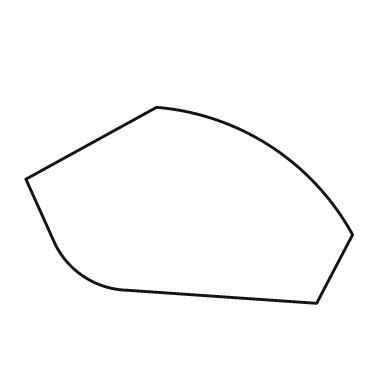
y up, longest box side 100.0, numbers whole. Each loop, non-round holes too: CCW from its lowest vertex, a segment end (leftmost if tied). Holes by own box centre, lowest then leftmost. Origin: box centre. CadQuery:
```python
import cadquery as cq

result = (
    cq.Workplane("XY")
    .moveTo(39.0, -30.0)
    .lineTo(50.0, -9.0)
    .threePointArc((25.0, 18.0), (-10.0, 30.0))
    .lineTo(-50.0, 8.0)
    .lineTo(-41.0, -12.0)
    .threePointArc((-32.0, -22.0), (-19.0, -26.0))
    .close()
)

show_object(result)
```